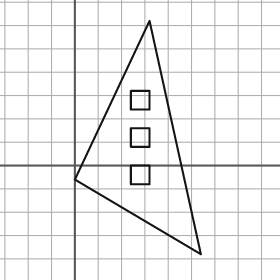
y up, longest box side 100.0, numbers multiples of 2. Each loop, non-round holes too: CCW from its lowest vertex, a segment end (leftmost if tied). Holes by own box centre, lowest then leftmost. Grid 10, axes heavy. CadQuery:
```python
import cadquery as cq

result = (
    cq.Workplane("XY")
    .moveTo(54.0, -38.0)
    .lineTo(32.0, 62.0)
    .lineTo(0.0, -6.0)
    .close()
    .moveTo(24.0, -8.0)
    .lineTo(32.0, -8.0)
    .lineTo(32.0, 0.0)
    .lineTo(24.0, 0.0)
    .close()
    .moveTo(24.0, 8.0)
    .lineTo(32.0, 8.0)
    .lineTo(32.0, 16.0)
    .lineTo(24.0, 16.0)
    .close()
    .moveTo(24.0, 24.0)
    .lineTo(32.0, 24.0)
    .lineTo(32.0, 32.0)
    .lineTo(24.0, 32.0)
    .close()
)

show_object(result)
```